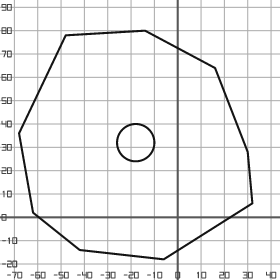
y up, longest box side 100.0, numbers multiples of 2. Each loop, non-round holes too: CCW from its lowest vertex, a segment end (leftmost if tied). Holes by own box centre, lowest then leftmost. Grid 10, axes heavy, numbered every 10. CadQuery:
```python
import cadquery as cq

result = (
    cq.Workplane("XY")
    .moveTo(-6.0, -18.0)
    .lineTo(32.0, 6.0)
    .lineTo(30.0, 28.0)
    .lineTo(16.0, 64.0)
    .lineTo(-14.0, 80.0)
    .lineTo(-48.0, 78.0)
    .lineTo(-68.0, 36.0)
    .lineTo(-62.0, 2.0)
    .lineTo(-42.0, -14.0)
    .close()
    .moveTo(-18.0, 32.0)
    .circle(8.0)
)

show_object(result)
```